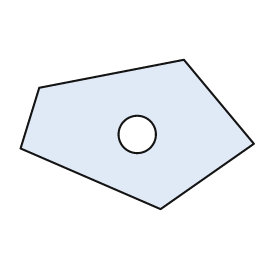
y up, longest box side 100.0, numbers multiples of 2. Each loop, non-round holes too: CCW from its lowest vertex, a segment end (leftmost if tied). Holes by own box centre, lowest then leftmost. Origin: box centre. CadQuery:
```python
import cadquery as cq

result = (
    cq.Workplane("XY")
    .moveTo(10.0, -32.0)
    .lineTo(50.0, -4.0)
    .lineTo(20.0, 32.0)
    .lineTo(-42.0, 20.0)
    .lineTo(-50.0, -6.0)
    .close()
    .moveTo(0.0, 0.0)
    .circle(8.0)
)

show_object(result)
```